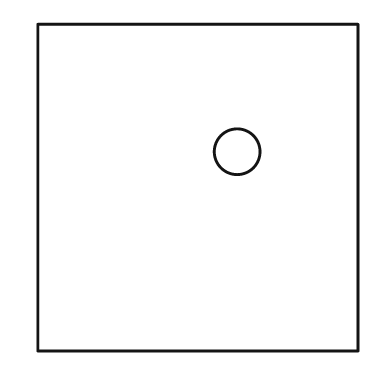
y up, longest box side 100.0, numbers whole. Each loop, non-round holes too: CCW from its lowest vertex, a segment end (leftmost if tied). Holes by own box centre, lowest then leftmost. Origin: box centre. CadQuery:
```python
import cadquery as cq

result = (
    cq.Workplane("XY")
    .moveTo(-49.0, -50.0)
    .lineTo(49.0, -50.0)
    .lineTo(49.0, 50.0)
    .lineTo(-49.0, 50.0)
    .close()
    .moveTo(12.0, 11.0)
    .circle(7.0)
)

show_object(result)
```